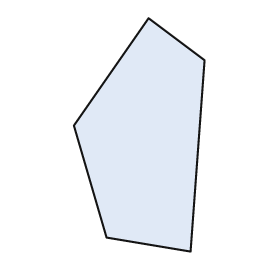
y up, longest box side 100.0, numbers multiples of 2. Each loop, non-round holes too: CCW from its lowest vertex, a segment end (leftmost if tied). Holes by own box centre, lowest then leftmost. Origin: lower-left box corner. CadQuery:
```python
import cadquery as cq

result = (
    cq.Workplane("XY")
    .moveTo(50.0, 0.0)
    .lineTo(56.0, 82.0)
    .lineTo(32.0, 100.0)
    .lineTo(0.0, 54.0)
    .lineTo(14.0, 6.0)
    .close()
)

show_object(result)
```